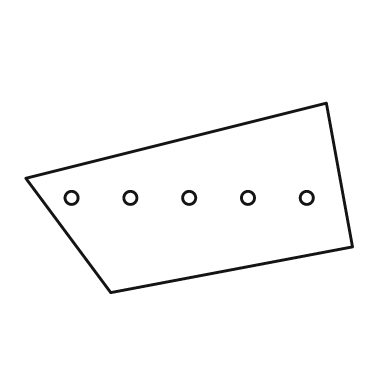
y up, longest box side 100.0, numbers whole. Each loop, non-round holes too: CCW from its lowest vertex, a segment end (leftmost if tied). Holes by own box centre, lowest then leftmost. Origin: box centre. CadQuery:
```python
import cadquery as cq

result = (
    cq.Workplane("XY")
    .moveTo(-24.0, -29.0)
    .lineTo(50.0, -15.0)
    .lineTo(42.0, 29.0)
    .lineTo(-50.0, 6.0)
    .close()
    .moveTo(-36.0, 0.0)
    .circle(2.0)
    .moveTo(-18.0, 0.0)
    .circle(2.0)
    .moveTo(0.0, 0.0)
    .circle(2.0)
    .moveTo(18.0, 0.0)
    .circle(2.0)
    .moveTo(36.0, 0.0)
    .circle(2.0)
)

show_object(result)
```